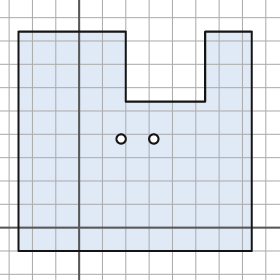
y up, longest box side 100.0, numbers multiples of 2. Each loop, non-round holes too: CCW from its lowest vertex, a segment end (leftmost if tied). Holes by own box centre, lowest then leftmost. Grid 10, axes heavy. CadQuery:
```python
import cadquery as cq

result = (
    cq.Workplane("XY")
    .moveTo(-26.0, -10.0)
    .lineTo(74.0, -10.0)
    .lineTo(74.0, 84.0)
    .lineTo(54.0, 84.0)
    .lineTo(54.0, 54.0)
    .lineTo(20.0, 54.0)
    .lineTo(20.0, 84.0)
    .lineTo(-26.0, 84.0)
    .close()
    .moveTo(18.0, 38.0)
    .circle(2.0)
    .moveTo(32.0, 38.0)
    .circle(2.0)
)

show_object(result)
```